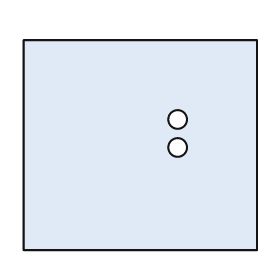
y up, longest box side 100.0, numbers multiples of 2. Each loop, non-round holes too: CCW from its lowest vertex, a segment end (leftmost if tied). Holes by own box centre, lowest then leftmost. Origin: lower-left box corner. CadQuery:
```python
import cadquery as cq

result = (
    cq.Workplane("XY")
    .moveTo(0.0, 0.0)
    .lineTo(100.0, 0.0)
    .lineTo(100.0, 90.0)
    .lineTo(0.0, 90.0)
    .close()
    .moveTo(66.0, 44.0)
    .circle(4.0)
    .moveTo(66.0, 56.0)
    .circle(4.0)
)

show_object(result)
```